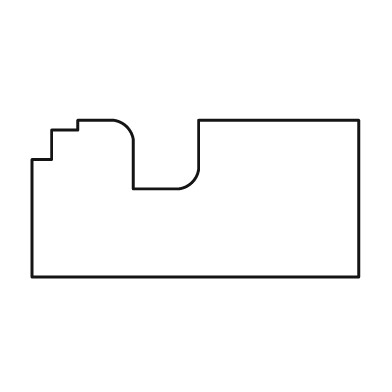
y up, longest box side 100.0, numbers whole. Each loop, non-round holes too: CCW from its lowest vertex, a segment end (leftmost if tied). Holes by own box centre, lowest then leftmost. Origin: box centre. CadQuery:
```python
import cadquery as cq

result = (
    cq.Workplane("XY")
    .moveTo(-50.0, -24.0)
    .lineTo(50.0, -24.0)
    .lineTo(50.0, 24.0)
    .lineTo(1.0, 24.0)
    .lineTo(1.0, 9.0)
    .threePointArc((-1.0, 5.0), (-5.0, 3.0))
    .lineTo(-19.0, 3.0)
    .lineTo(-19.0, 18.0)
    .threePointArc((-21.0, 22.0), (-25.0, 24.0))
    .lineTo(-36.0, 24.0)
    .lineTo(-36.0, 21.0)
    .lineTo(-44.0, 21.0)
    .lineTo(-44.0, 12.0)
    .lineTo(-50.0, 12.0)
    .close()
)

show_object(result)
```